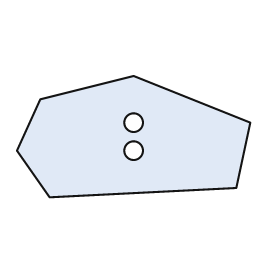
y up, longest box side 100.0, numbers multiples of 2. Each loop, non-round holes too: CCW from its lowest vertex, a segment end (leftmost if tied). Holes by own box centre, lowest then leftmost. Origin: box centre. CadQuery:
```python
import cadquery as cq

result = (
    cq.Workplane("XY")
    .moveTo(-36.0, -26.0)
    .lineTo(44.0, -22.0)
    .lineTo(50.0, 6.0)
    .lineTo(0.0, 26.0)
    .lineTo(-40.0, 16.0)
    .lineTo(-50.0, -6.0)
    .close()
    .moveTo(0.0, -6.0)
    .circle(4.0)
    .moveTo(0.0, 6.0)
    .circle(4.0)
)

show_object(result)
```